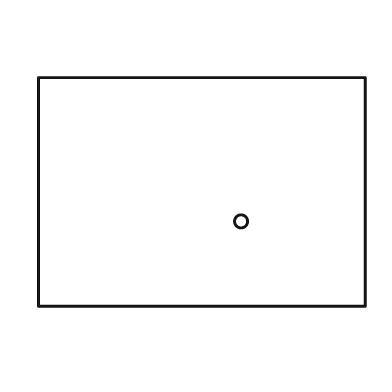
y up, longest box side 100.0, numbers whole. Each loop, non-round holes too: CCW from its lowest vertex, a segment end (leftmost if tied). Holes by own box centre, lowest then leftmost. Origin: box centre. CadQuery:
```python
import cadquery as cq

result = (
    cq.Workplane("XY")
    .moveTo(-50.0, -35.0)
    .lineTo(50.0, -35.0)
    .lineTo(50.0, 35.0)
    .lineTo(-50.0, 35.0)
    .close()
    .moveTo(12.0, -9.0)
    .circle(2.0)
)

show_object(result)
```